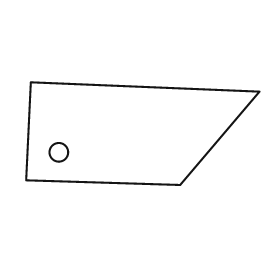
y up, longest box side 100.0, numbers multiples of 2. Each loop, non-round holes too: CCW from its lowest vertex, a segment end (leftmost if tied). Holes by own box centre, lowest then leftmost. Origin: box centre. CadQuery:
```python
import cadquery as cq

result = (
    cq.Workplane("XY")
    .moveTo(16.0, -22.0)
    .lineTo(50.0, 18.0)
    .lineTo(-48.0, 22.0)
    .lineTo(-50.0, -20.0)
    .close()
    .moveTo(-36.0, -8.0)
    .circle(4.0)
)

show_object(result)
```